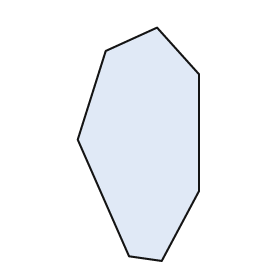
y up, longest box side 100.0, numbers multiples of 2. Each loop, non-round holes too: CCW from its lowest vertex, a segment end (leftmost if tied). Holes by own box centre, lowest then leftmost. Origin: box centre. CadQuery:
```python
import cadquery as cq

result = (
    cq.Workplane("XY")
    .moveTo(10.0, -50.0)
    .lineTo(26.0, -20.0)
    .lineTo(26.0, 30.0)
    .lineTo(8.0, 50.0)
    .lineTo(-14.0, 40.0)
    .lineTo(-26.0, 2.0)
    .lineTo(-4.0, -48.0)
    .close()
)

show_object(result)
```